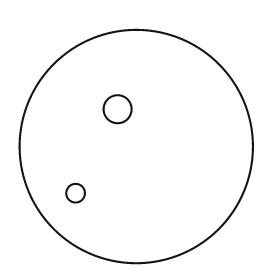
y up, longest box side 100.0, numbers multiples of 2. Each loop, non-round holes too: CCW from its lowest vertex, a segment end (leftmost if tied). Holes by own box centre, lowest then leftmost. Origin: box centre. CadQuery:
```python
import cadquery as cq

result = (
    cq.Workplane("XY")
    .moveTo(0.0, 0.0)
    .circle(50.0)
    .moveTo(-26.0, -20.0)
    .circle(4.0)
    .moveTo(-8.0, 16.0)
    .circle(6.0)
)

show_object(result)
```